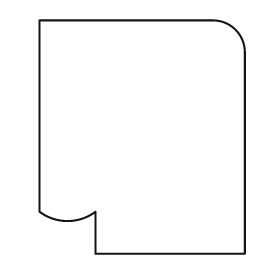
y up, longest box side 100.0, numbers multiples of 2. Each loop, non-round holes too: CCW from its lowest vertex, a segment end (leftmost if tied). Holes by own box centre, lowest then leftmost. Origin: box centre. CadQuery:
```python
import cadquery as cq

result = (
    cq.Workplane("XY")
    .moveTo(-20.0, -50.0)
    .lineTo(44.0, -50.0)
    .lineTo(44.0, 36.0)
    .threePointArc((40.0, 46.0), (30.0, 50.0))
    .lineTo(-44.0, 50.0)
    .lineTo(-44.0, -32.0)
    .threePointArc((-32.0, -36.0), (-20.0, -32.0))
    .close()
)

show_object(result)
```